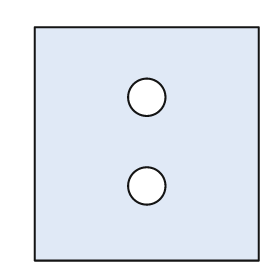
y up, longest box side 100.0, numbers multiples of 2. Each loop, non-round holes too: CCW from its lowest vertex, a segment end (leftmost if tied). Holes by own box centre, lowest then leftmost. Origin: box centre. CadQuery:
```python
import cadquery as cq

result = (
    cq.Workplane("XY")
    .moveTo(-48.0, -50.0)
    .lineTo(48.0, -50.0)
    .lineTo(48.0, 50.0)
    .lineTo(-48.0, 50.0)
    .close()
    .moveTo(0.0, -18.0)
    .circle(8.0)
    .moveTo(0.0, 20.0)
    .circle(8.0)
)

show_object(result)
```